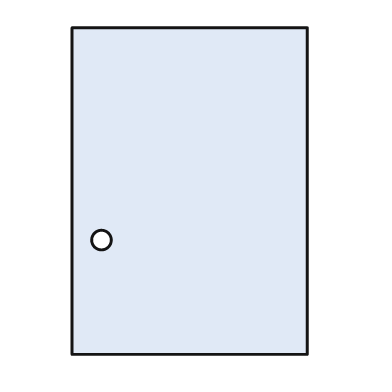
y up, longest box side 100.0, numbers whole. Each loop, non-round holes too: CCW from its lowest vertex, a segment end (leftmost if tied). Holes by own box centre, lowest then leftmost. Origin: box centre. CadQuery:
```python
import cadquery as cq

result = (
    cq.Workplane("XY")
    .moveTo(-36.0, -50.0)
    .lineTo(36.0, -50.0)
    .lineTo(36.0, 50.0)
    .lineTo(-36.0, 50.0)
    .close()
    .moveTo(-27.0, -15.0)
    .circle(3.0)
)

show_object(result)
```